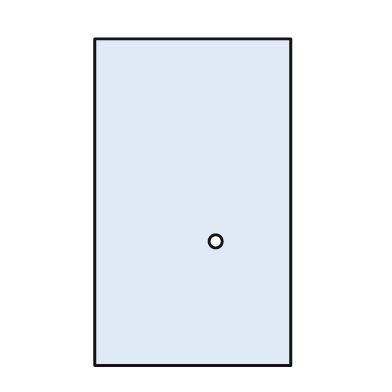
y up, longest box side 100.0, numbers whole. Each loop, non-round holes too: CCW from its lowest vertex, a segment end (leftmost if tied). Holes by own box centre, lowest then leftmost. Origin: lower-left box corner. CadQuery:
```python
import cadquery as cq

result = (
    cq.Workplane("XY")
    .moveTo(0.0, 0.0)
    .lineTo(60.0, 0.0)
    .lineTo(60.0, 100.0)
    .lineTo(0.0, 100.0)
    .close()
    .moveTo(37.0, 38.0)
    .circle(2.0)
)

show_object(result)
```